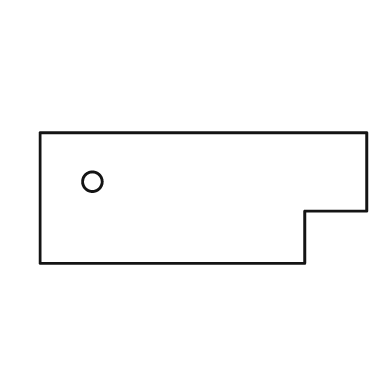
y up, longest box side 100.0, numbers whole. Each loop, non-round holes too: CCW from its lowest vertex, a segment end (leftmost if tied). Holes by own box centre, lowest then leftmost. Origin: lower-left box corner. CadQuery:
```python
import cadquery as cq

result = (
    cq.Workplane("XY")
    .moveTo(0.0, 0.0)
    .lineTo(81.0, 0.0)
    .lineTo(81.0, 16.0)
    .lineTo(100.0, 16.0)
    .lineTo(100.0, 40.0)
    .lineTo(0.0, 40.0)
    .close()
    .moveTo(16.0, 25.0)
    .circle(3.0)
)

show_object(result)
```